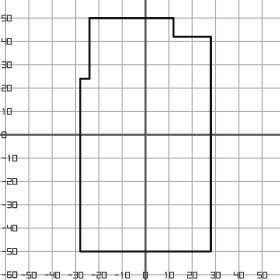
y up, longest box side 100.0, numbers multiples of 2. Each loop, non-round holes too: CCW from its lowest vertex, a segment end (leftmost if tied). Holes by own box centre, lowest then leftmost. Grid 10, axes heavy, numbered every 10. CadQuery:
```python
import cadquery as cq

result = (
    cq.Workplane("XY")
    .moveTo(-28.0, -50.0)
    .lineTo(28.0, -50.0)
    .lineTo(28.0, 42.0)
    .lineTo(12.0, 42.0)
    .lineTo(12.0, 50.0)
    .lineTo(-24.0, 50.0)
    .lineTo(-24.0, 24.0)
    .lineTo(-28.0, 24.0)
    .close()
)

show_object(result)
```